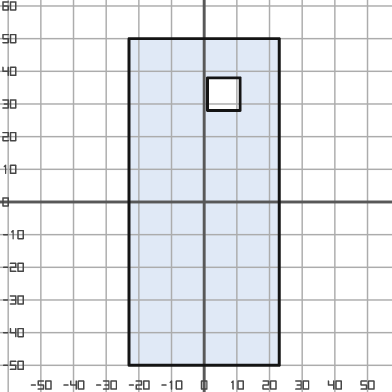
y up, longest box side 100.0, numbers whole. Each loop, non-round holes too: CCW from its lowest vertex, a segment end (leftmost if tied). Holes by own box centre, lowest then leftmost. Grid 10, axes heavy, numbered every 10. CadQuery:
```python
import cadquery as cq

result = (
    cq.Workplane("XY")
    .moveTo(-23.0, -50.0)
    .lineTo(23.0, -50.0)
    .lineTo(23.0, 50.0)
    .lineTo(-23.0, 50.0)
    .close()
    .moveTo(1.0, 28.0)
    .lineTo(11.0, 28.0)
    .lineTo(11.0, 38.0)
    .lineTo(1.0, 38.0)
    .close()
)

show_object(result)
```